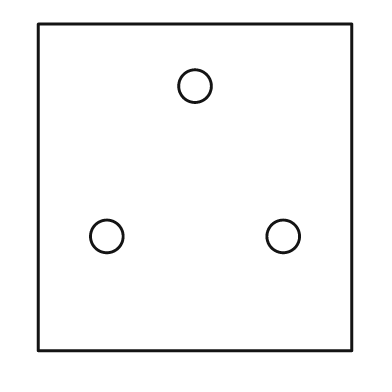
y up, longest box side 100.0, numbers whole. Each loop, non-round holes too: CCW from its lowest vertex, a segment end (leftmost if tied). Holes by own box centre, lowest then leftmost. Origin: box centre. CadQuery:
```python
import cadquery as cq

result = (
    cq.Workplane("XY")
    .moveTo(-48.0, -50.0)
    .lineTo(48.0, -50.0)
    .lineTo(48.0, 50.0)
    .lineTo(-48.0, 50.0)
    .close()
    .moveTo(-27.0, -15.0)
    .circle(5.0)
    .moveTo(27.0, -15.0)
    .circle(5.0)
    .moveTo(0.0, 31.0)
    .circle(5.0)
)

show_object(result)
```